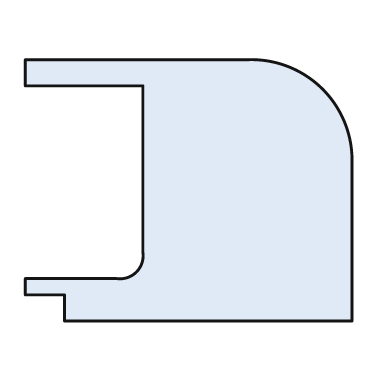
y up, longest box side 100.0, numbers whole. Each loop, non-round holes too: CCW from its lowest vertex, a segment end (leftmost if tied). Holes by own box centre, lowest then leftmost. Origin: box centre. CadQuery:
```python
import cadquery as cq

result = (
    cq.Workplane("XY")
    .moveTo(-38.0, -40.0)
    .lineTo(50.0, -40.0)
    .lineTo(50.0, 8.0)
    .threePointArc((41.0, 31.0), (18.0, 40.0))
    .lineTo(-50.0, 40.0)
    .lineTo(-50.0, 32.0)
    .lineTo(-14.0, 32.0)
    .lineTo(-14.0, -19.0)
    .threePointArc((-16.0, -25.0), (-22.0, -27.0))
    .lineTo(-50.0, -27.0)
    .lineTo(-50.0, -32.0)
    .lineTo(-38.0, -32.0)
    .close()
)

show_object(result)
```